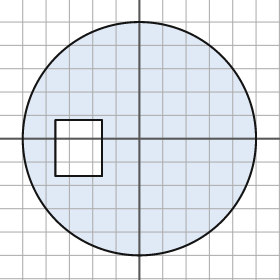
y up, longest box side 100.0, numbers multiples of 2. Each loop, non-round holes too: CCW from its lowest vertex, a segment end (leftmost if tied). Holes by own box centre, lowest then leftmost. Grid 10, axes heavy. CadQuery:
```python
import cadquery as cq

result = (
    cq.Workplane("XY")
    .moveTo(0.0, 0.0)
    .circle(50.0)
    .moveTo(-36.0, -16.0)
    .lineTo(-16.0, -16.0)
    .lineTo(-16.0, 8.0)
    .lineTo(-36.0, 8.0)
    .close()
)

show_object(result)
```